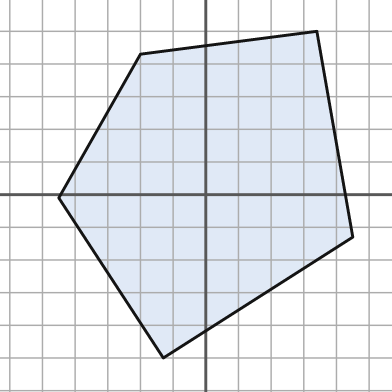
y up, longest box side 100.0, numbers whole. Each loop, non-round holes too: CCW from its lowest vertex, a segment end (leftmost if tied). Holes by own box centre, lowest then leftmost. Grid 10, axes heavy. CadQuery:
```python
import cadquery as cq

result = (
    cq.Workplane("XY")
    .moveTo(-13.0, -50.0)
    .lineTo(45.0, -13.0)
    .lineTo(34.0, 50.0)
    .lineTo(-20.0, 43.0)
    .lineTo(-45.0, -1.0)
    .close()
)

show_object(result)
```